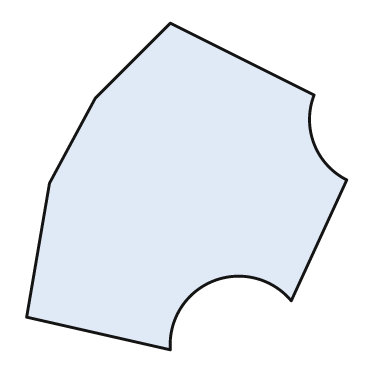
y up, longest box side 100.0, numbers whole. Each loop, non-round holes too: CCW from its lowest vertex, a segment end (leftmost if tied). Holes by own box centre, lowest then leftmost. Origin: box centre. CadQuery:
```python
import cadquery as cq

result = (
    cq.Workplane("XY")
    .moveTo(-5.0, -50.0)
    .threePointArc((8.0, -29.0), (32.0, -35.0))
    .lineTo(49.0, 2.0)
    .threePointArc((39.0, 13.0), (39.0, 28.0))
    .lineTo(-5.0, 50.0)
    .lineTo(-28.0, 27.0)
    .lineTo(-42.0, 1.0)
    .lineTo(-49.0, -40.0)
    .close()
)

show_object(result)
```